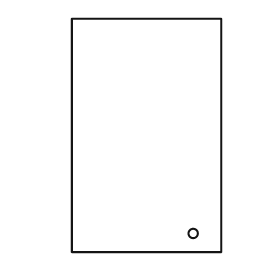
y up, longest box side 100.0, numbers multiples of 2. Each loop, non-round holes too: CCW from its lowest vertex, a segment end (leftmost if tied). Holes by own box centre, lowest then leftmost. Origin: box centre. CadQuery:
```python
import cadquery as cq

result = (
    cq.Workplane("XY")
    .moveTo(-32.0, -50.0)
    .lineTo(32.0, -50.0)
    .lineTo(32.0, 50.0)
    .lineTo(-32.0, 50.0)
    .close()
    .moveTo(20.0, -42.0)
    .circle(2.0)
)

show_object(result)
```